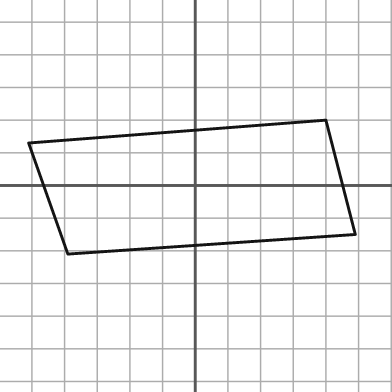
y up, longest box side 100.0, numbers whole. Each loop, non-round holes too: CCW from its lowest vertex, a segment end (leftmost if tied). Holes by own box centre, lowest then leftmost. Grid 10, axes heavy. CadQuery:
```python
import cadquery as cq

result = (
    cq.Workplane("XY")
    .moveTo(-39.0, -21.0)
    .lineTo(49.0, -15.0)
    .lineTo(40.0, 20.0)
    .lineTo(-51.0, 13.0)
    .close()
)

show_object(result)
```